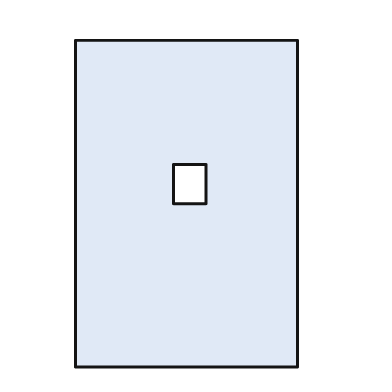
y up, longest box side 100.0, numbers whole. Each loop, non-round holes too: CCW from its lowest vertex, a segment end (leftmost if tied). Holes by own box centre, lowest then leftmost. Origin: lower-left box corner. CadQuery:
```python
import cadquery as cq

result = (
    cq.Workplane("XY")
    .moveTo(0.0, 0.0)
    .lineTo(68.0, 0.0)
    .lineTo(68.0, 100.0)
    .lineTo(0.0, 100.0)
    .close()
    .moveTo(30.0, 50.0)
    .lineTo(40.0, 50.0)
    .lineTo(40.0, 62.0)
    .lineTo(30.0, 62.0)
    .close()
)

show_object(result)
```